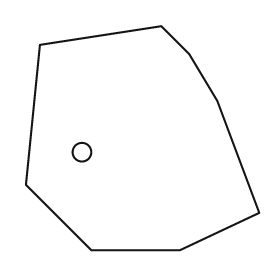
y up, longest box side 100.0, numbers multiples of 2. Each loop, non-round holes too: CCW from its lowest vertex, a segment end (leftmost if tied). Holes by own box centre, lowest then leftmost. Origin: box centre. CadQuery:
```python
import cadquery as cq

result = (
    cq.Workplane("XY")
    .moveTo(-22.0, -48.0)
    .lineTo(16.0, -48.0)
    .lineTo(50.0, -32.0)
    .lineTo(32.0, 16.0)
    .lineTo(20.0, 36.0)
    .lineTo(8.0, 48.0)
    .lineTo(-44.0, 40.0)
    .lineTo(-50.0, -20.0)
    .close()
    .moveTo(-26.0, -6.0)
    .circle(4.0)
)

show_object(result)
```